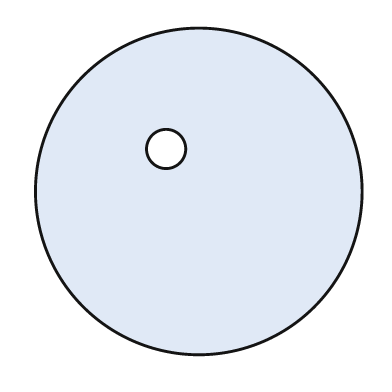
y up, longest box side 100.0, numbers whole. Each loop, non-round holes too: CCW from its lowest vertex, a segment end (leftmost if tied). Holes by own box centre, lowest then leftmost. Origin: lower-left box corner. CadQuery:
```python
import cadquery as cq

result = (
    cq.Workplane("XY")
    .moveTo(50.0, 50.0)
    .circle(50.0)
    .moveTo(40.0, 63.0)
    .circle(6.0)
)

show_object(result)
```